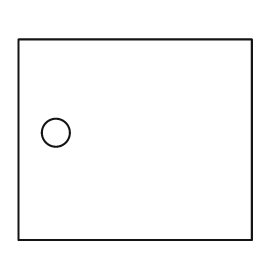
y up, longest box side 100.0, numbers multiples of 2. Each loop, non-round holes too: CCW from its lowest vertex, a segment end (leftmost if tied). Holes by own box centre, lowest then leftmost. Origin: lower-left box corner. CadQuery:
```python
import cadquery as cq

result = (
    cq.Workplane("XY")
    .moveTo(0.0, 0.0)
    .lineTo(100.0, 0.0)
    .lineTo(100.0, 86.0)
    .lineTo(0.0, 86.0)
    .close()
    .moveTo(16.0, 46.0)
    .circle(6.0)
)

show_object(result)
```